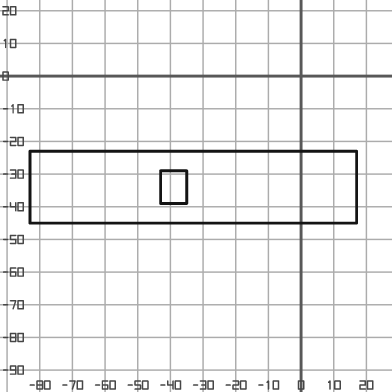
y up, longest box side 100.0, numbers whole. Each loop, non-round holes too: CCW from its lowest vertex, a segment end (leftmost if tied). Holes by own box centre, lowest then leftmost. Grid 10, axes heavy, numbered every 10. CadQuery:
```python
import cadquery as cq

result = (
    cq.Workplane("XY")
    .moveTo(-83.0, -45.0)
    .lineTo(17.0, -45.0)
    .lineTo(17.0, -23.0)
    .lineTo(-83.0, -23.0)
    .close()
    .moveTo(-43.0, -39.0)
    .lineTo(-35.0, -39.0)
    .lineTo(-35.0, -29.0)
    .lineTo(-43.0, -29.0)
    .close()
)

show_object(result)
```